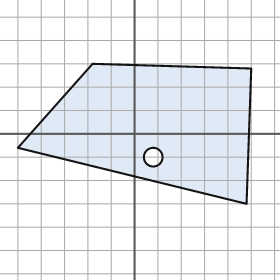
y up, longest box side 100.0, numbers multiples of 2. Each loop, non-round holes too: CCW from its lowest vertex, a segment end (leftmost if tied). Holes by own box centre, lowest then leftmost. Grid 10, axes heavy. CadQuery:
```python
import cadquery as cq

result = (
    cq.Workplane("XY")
    .moveTo(48.0, -30.0)
    .lineTo(50.0, 28.0)
    .lineTo(-18.0, 30.0)
    .lineTo(-50.0, -6.0)
    .close()
    .moveTo(8.0, -10.0)
    .circle(4.0)
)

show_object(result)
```